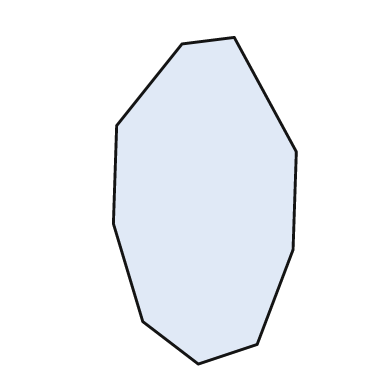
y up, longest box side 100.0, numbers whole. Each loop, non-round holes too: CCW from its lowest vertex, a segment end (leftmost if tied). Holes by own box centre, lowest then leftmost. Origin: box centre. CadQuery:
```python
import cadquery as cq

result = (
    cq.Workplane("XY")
    .moveTo(-2.0, -50.0)
    .lineTo(16.0, -44.0)
    .lineTo(27.0, -15.0)
    .lineTo(28.0, 15.0)
    .lineTo(9.0, 50.0)
    .lineTo(-7.0, 48.0)
    .lineTo(-27.0, 23.0)
    .lineTo(-28.0, -7.0)
    .lineTo(-19.0, -37.0)
    .close()
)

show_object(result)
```